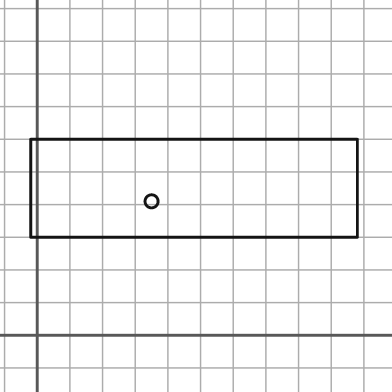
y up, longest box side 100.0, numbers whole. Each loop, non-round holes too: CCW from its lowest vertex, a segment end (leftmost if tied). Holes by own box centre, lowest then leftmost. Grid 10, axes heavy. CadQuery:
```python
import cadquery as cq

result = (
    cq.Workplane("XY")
    .moveTo(-2.0, 30.0)
    .lineTo(98.0, 30.0)
    .lineTo(98.0, 60.0)
    .lineTo(-2.0, 60.0)
    .close()
    .moveTo(35.0, 41.0)
    .circle(2.0)
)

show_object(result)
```